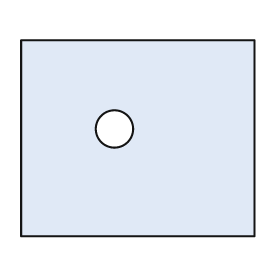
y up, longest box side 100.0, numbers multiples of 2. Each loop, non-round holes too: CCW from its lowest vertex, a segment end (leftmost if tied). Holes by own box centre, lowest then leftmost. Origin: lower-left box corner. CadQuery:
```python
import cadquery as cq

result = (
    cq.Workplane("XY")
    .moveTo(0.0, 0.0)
    .lineTo(100.0, 0.0)
    .lineTo(100.0, 84.0)
    .lineTo(0.0, 84.0)
    .close()
    .moveTo(40.0, 46.0)
    .circle(8.0)
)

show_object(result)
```